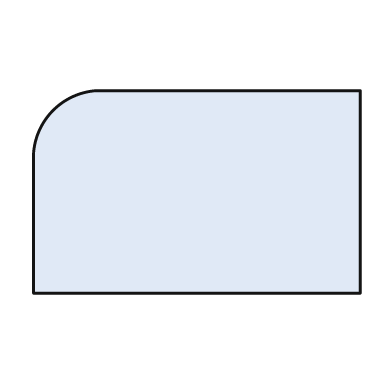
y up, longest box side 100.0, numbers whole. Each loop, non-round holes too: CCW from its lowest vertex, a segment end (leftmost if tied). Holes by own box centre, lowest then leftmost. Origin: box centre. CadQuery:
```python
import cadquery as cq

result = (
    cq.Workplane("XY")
    .moveTo(-50.0, -31.0)
    .lineTo(50.0, -31.0)
    .lineTo(50.0, 31.0)
    .lineTo(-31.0, 31.0)
    .threePointArc((-44.0, 25.0), (-50.0, 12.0))
    .close()
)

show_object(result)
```